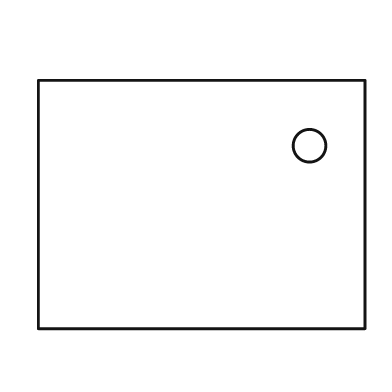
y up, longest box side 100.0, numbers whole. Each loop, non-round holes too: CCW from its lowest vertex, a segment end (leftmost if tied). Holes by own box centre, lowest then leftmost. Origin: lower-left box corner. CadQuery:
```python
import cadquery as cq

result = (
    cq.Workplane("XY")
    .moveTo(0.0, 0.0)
    .lineTo(100.0, 0.0)
    .lineTo(100.0, 76.0)
    .lineTo(0.0, 76.0)
    .close()
    .moveTo(83.0, 56.0)
    .circle(5.0)
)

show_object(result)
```